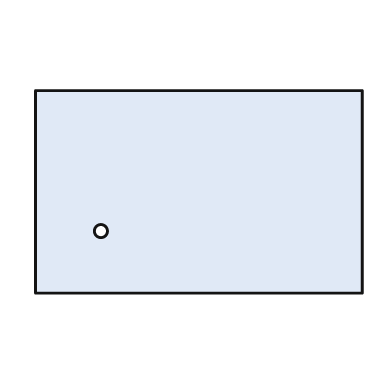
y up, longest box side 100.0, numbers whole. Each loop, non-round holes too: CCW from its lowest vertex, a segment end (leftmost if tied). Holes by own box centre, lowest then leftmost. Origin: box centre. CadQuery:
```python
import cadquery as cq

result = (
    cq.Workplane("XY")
    .moveTo(-50.0, -31.0)
    .lineTo(50.0, -31.0)
    .lineTo(50.0, 31.0)
    .lineTo(-50.0, 31.0)
    .close()
    .moveTo(-30.0, -12.0)
    .circle(2.0)
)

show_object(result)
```